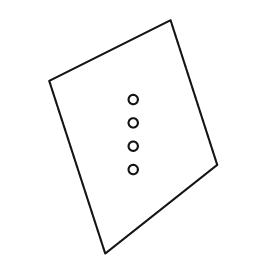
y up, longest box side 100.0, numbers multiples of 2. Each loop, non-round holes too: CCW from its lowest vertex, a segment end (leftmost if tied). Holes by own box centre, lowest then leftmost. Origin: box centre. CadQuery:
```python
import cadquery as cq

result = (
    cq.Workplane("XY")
    .moveTo(-12.0, -50.0)
    .lineTo(36.0, -12.0)
    .lineTo(16.0, 50.0)
    .lineTo(-36.0, 24.0)
    .close()
    .moveTo(0.0, -14.0)
    .circle(2.0)
    .moveTo(0.0, -4.0)
    .circle(2.0)
    .moveTo(0.0, 6.0)
    .circle(2.0)
    .moveTo(0.0, 16.0)
    .circle(2.0)
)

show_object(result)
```